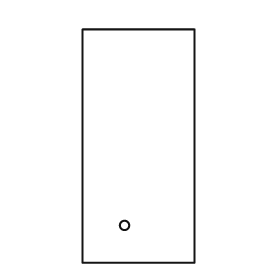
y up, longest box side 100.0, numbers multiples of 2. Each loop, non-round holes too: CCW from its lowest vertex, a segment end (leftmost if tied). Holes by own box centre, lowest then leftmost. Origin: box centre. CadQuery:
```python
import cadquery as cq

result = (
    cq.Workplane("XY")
    .moveTo(-24.0, -50.0)
    .lineTo(24.0, -50.0)
    .lineTo(24.0, 50.0)
    .lineTo(-24.0, 50.0)
    .close()
    .moveTo(-6.0, -34.0)
    .circle(2.0)
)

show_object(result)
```